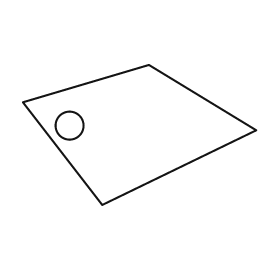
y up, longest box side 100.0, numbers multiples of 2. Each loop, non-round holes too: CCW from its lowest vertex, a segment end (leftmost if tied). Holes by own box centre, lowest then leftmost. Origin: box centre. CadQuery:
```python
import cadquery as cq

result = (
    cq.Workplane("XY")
    .moveTo(-16.0, -30.0)
    .lineTo(50.0, 2.0)
    .lineTo(4.0, 30.0)
    .lineTo(-50.0, 14.0)
    .close()
    .moveTo(-30.0, 4.0)
    .circle(6.0)
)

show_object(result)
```